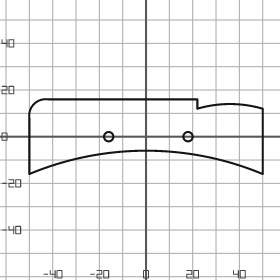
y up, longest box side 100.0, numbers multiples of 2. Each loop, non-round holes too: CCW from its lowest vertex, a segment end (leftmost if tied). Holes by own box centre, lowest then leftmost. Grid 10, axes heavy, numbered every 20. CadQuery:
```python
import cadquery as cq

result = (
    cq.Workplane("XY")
    .moveTo(-50.0, -16.0)
    .threePointArc((0.0, -6.0), (50.0, -16.0))
    .lineTo(50.0, 12.0)
    .threePointArc((36.0, 14.0), (22.0, 12.0))
    .lineTo(22.0, 16.0)
    .lineTo(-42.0, 16.0)
    .threePointArc((-48.0, 14.0), (-50.0, 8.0))
    .close()
    .moveTo(-16.0, 0.0)
    .circle(2.0)
    .moveTo(18.0, 0.0)
    .circle(2.0)
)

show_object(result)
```